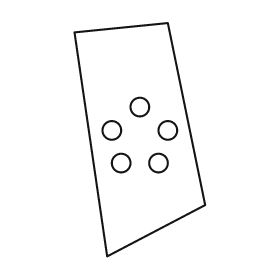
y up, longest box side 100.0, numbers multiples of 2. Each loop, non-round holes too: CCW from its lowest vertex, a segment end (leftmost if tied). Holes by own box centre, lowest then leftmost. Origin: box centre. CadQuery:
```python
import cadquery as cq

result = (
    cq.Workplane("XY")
    .moveTo(-14.0, -50.0)
    .lineTo(28.0, -28.0)
    .lineTo(12.0, 50.0)
    .lineTo(-28.0, 46.0)
    .close()
    .moveTo(-8.0, -10.0)
    .circle(4.0)
    .moveTo(8.0, -10.0)
    .circle(4.0)
    .moveTo(-12.0, 4.0)
    .circle(4.0)
    .moveTo(12.0, 4.0)
    .circle(4.0)
    .moveTo(0.0, 14.0)
    .circle(4.0)
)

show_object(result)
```